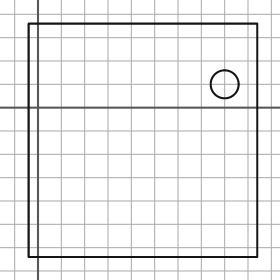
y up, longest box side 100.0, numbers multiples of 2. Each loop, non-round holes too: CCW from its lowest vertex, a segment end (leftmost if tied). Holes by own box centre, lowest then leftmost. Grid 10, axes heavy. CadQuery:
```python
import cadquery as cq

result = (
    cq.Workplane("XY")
    .moveTo(-4.0, -64.0)
    .lineTo(94.0, -64.0)
    .lineTo(94.0, 36.0)
    .lineTo(-4.0, 36.0)
    .close()
    .moveTo(80.0, 10.0)
    .circle(6.0)
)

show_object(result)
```